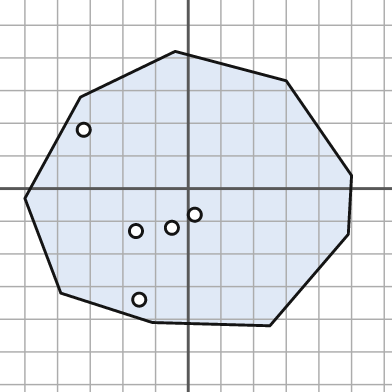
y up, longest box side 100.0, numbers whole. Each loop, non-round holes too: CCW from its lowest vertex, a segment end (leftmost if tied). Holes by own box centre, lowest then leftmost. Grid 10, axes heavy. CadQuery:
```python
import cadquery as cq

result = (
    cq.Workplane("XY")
    .moveTo(25.0, -42.0)
    .lineTo(49.0, -14.0)
    .lineTo(50.0, 4.0)
    .lineTo(30.0, 33.0)
    .lineTo(-4.0, 42.0)
    .lineTo(-33.0, 28.0)
    .lineTo(-50.0, -3.0)
    .lineTo(-39.0, -32.0)
    .lineTo(-11.0, -41.0)
    .close()
    .moveTo(-15.0, -34.0)
    .circle(2.0)
    .moveTo(-16.0, -13.0)
    .circle(2.0)
    .moveTo(-5.0, -12.0)
    .circle(2.0)
    .moveTo(2.0, -8.0)
    .circle(2.0)
    .moveTo(-32.0, 18.0)
    .circle(2.0)
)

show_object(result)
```